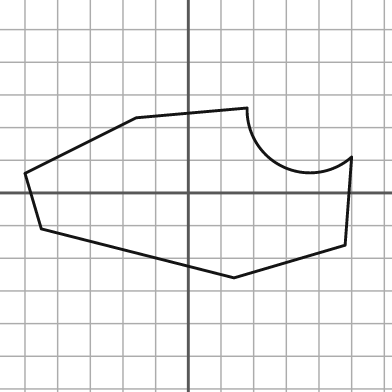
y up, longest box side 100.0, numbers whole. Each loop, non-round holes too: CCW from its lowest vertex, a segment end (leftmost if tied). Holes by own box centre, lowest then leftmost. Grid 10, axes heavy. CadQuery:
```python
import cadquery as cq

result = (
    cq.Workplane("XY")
    .moveTo(14.0, -26.0)
    .lineTo(48.0, -16.0)
    .lineTo(50.0, 11.0)
    .threePointArc((29.0, 8.0), (18.0, 26.0))
    .lineTo(-16.0, 23.0)
    .lineTo(-50.0, 6.0)
    .lineTo(-45.0, -11.0)
    .close()
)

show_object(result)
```